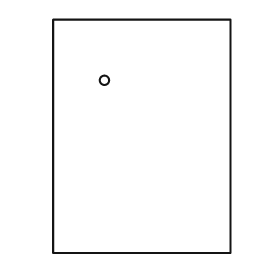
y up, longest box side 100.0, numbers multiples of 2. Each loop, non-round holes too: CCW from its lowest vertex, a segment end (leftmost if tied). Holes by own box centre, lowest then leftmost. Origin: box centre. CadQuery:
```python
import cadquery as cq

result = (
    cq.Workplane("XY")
    .moveTo(-38.0, -50.0)
    .lineTo(38.0, -50.0)
    .lineTo(38.0, 50.0)
    .lineTo(-38.0, 50.0)
    .close()
    .moveTo(-16.0, 24.0)
    .circle(2.0)
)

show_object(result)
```